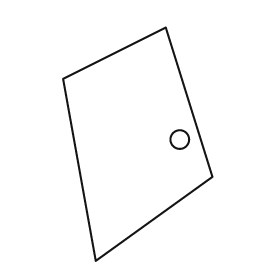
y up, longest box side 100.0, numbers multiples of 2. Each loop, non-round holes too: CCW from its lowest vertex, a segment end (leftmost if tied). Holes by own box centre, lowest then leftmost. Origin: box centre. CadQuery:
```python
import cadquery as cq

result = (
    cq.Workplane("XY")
    .moveTo(-18.0, -50.0)
    .lineTo(32.0, -14.0)
    .lineTo(12.0, 50.0)
    .lineTo(-32.0, 28.0)
    .close()
    .moveTo(18.0, 2.0)
    .circle(4.0)
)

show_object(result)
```